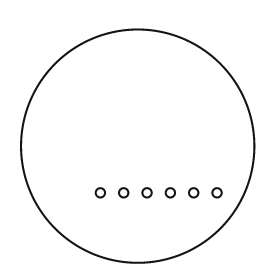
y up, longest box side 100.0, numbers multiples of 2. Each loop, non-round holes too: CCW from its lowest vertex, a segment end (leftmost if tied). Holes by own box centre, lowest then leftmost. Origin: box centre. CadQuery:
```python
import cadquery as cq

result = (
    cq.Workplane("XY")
    .moveTo(0.0, 0.0)
    .circle(50.0)
    .moveTo(-16.0, -20.0)
    .circle(2.0)
    .moveTo(-6.0, -20.0)
    .circle(2.0)
    .moveTo(4.0, -20.0)
    .circle(2.0)
    .moveTo(14.0, -20.0)
    .circle(2.0)
    .moveTo(24.0, -20.0)
    .circle(2.0)
    .moveTo(34.0, -20.0)
    .circle(2.0)
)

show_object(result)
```